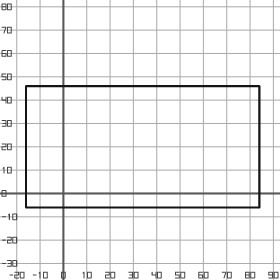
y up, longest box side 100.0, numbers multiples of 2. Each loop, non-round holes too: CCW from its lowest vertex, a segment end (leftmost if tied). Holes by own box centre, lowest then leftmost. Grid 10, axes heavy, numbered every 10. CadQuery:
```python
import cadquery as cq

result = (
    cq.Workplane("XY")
    .moveTo(-16.0, -6.0)
    .lineTo(84.0, -6.0)
    .lineTo(84.0, 46.0)
    .lineTo(-16.0, 46.0)
    .close()
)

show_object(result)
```